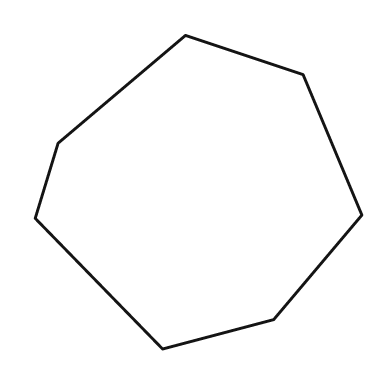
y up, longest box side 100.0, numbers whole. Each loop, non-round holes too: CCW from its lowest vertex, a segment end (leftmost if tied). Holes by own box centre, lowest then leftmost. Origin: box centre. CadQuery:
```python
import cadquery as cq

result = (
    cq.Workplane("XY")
    .moveTo(-11.0, -48.0)
    .lineTo(23.0, -39.0)
    .lineTo(50.0, -7.0)
    .lineTo(32.0, 36.0)
    .lineTo(-4.0, 48.0)
    .lineTo(-43.0, 15.0)
    .lineTo(-50.0, -8.0)
    .close()
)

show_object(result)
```